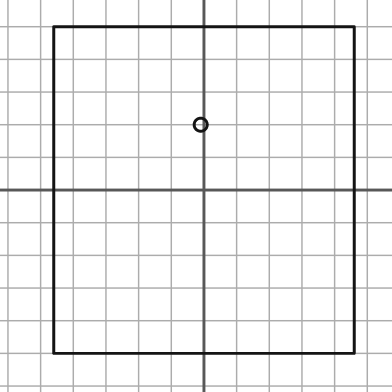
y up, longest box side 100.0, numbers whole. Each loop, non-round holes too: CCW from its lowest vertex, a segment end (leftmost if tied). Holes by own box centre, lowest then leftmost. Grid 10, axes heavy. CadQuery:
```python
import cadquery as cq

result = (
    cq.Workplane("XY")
    .moveTo(-46.0, -50.0)
    .lineTo(46.0, -50.0)
    .lineTo(46.0, 50.0)
    .lineTo(-46.0, 50.0)
    .close()
    .moveTo(-1.0, 20.0)
    .circle(2.0)
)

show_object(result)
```